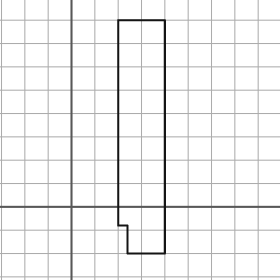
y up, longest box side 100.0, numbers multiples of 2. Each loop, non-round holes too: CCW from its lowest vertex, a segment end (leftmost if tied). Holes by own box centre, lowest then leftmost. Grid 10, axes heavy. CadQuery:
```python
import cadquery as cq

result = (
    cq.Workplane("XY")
    .moveTo(24.0, -20.0)
    .lineTo(40.0, -20.0)
    .lineTo(40.0, 80.0)
    .lineTo(20.0, 80.0)
    .lineTo(20.0, -8.0)
    .lineTo(24.0, -8.0)
    .close()
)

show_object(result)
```